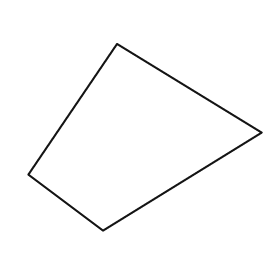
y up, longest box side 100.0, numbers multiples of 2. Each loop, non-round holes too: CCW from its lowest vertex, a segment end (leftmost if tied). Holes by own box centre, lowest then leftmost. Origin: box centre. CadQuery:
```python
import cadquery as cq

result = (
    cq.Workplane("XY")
    .moveTo(-18.0, -40.0)
    .lineTo(50.0, 2.0)
    .lineTo(-12.0, 40.0)
    .lineTo(-50.0, -16.0)
    .close()
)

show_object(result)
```